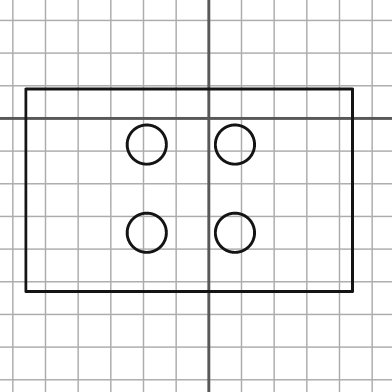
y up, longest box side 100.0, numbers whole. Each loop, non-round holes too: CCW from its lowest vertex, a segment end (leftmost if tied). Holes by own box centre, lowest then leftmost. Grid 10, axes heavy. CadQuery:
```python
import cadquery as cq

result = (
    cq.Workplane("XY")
    .moveTo(-56.0, -53.0)
    .lineTo(44.0, -53.0)
    .lineTo(44.0, 9.0)
    .lineTo(-56.0, 9.0)
    .close()
    .moveTo(-19.0, -35.0)
    .circle(6.0)
    .moveTo(8.0, -35.0)
    .circle(6.0)
    .moveTo(-19.0, -8.0)
    .circle(6.0)
    .moveTo(8.0, -8.0)
    .circle(6.0)
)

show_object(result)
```